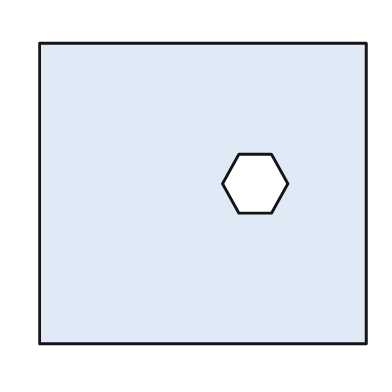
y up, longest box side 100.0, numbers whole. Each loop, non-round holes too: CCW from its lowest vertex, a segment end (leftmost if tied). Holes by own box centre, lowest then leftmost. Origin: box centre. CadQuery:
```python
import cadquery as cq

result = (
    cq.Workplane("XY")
    .moveTo(-50.0, -46.0)
    .lineTo(50.0, -46.0)
    .lineTo(50.0, 46.0)
    .lineTo(-50.0, 46.0)
    .close()
    .moveTo(11.0, -6.0)
    .lineTo(21.0, -6.0)
    .lineTo(26.0, 3.0)
    .lineTo(21.0, 12.0)
    .lineTo(11.0, 12.0)
    .lineTo(6.0, 3.0)
    .close()
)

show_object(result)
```